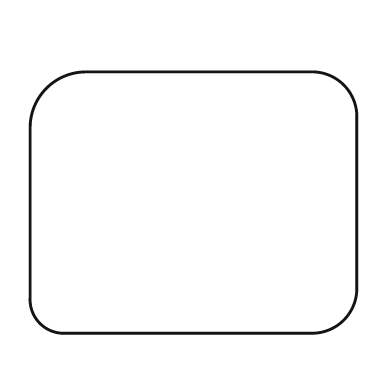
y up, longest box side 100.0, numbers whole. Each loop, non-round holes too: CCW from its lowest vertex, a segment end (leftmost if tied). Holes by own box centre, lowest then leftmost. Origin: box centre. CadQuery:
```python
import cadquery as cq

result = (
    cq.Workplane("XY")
    .moveTo(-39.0, -40.0)
    .lineTo(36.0, -40.0)
    .threePointArc((46.0, -36.0), (50.0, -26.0))
    .lineTo(50.0, 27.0)
    .threePointArc((46.0, 36.0), (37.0, 40.0))
    .lineTo(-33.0, 40.0)
    .threePointArc((-45.0, 35.0), (-50.0, 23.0))
    .lineTo(-50.0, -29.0)
    .threePointArc((-47.0, -37.0), (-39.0, -40.0))
    .close()
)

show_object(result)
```